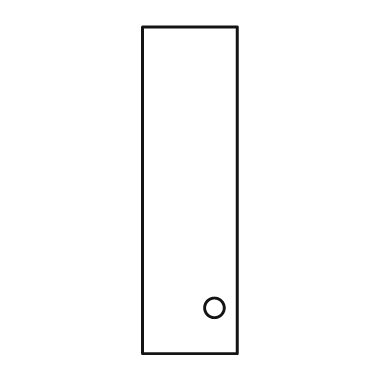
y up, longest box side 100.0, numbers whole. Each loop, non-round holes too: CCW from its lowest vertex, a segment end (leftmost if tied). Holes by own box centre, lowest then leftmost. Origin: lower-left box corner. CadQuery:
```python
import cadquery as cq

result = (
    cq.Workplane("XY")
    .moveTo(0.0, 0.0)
    .lineTo(29.0, 0.0)
    .lineTo(29.0, 100.0)
    .lineTo(0.0, 100.0)
    .close()
    .moveTo(22.0, 14.0)
    .circle(3.0)
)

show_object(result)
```